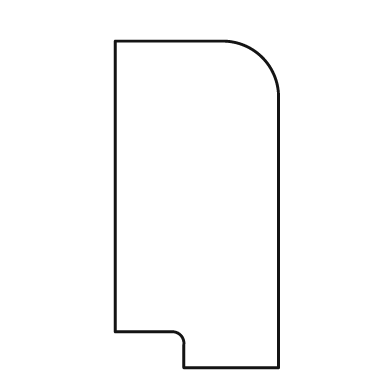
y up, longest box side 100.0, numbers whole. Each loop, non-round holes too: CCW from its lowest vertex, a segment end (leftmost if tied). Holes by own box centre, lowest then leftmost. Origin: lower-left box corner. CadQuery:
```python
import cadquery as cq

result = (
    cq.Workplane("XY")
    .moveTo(21.0, 0.0)
    .lineTo(50.0, 0.0)
    .lineTo(50.0, 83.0)
    .threePointArc((45.0, 95.0), (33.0, 100.0))
    .lineTo(0.0, 100.0)
    .lineTo(0.0, 11.0)
    .lineTo(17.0, 11.0)
    .threePointArc((20.0, 10.0), (21.0, 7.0))
    .close()
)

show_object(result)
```